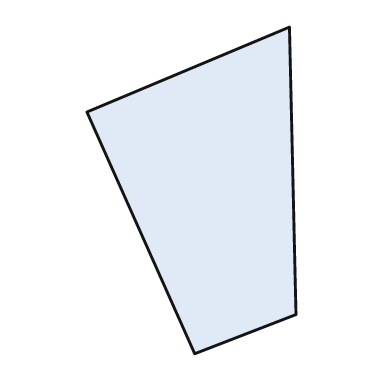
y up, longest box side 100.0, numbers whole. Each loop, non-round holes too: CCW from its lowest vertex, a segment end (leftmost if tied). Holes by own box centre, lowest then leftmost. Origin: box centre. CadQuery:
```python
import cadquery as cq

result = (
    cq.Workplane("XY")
    .moveTo(1.0, -50.0)
    .lineTo(32.0, -38.0)
    .lineTo(30.0, 50.0)
    .lineTo(-32.0, 24.0)
    .close()
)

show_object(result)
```